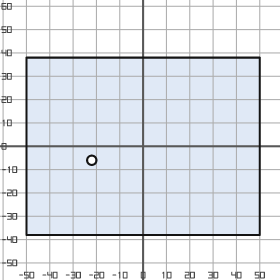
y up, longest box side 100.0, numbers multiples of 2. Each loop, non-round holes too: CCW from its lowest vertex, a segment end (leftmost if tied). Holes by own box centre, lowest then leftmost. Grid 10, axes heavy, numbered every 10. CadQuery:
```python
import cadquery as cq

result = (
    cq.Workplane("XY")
    .moveTo(-50.0, -38.0)
    .lineTo(50.0, -38.0)
    .lineTo(50.0, 38.0)
    .lineTo(-50.0, 38.0)
    .close()
    .moveTo(-22.0, -6.0)
    .circle(2.0)
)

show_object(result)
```